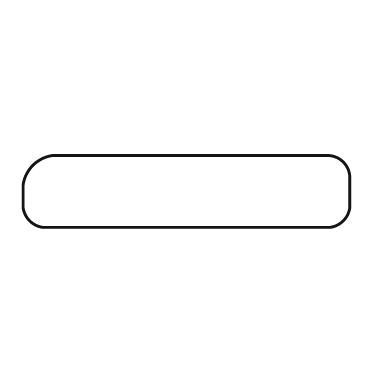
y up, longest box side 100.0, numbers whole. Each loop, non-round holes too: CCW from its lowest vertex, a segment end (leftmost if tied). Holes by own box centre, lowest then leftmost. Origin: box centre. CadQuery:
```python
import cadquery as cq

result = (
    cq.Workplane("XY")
    .moveTo(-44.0, -11.0)
    .lineTo(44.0, -11.0)
    .threePointArc((48.0, -9.0), (50.0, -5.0))
    .lineTo(50.0, 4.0)
    .threePointArc((48.0, 9.0), (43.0, 11.0))
    .lineTo(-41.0, 11.0)
    .threePointArc((-47.0, 8.0), (-50.0, 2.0))
    .lineTo(-50.0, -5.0)
    .threePointArc((-48.0, -9.0), (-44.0, -11.0))
    .close()
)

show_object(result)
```